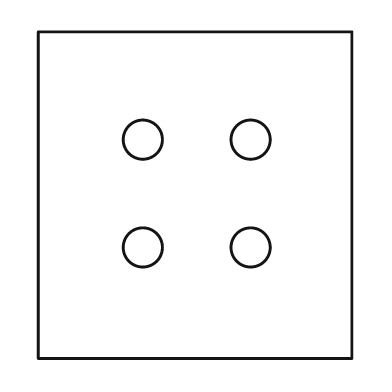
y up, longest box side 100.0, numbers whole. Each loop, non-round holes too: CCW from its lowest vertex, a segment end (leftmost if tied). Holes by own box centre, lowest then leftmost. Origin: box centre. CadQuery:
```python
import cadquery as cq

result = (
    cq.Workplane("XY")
    .moveTo(-48.0, -50.0)
    .lineTo(48.0, -50.0)
    .lineTo(48.0, 50.0)
    .lineTo(-48.0, 50.0)
    .close()
    .moveTo(-16.0, -16.0)
    .circle(6.0)
    .moveTo(17.0, -16.0)
    .circle(6.0)
    .moveTo(-16.0, 17.0)
    .circle(6.0)
    .moveTo(17.0, 17.0)
    .circle(6.0)
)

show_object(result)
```